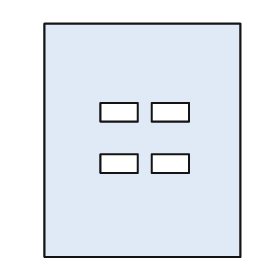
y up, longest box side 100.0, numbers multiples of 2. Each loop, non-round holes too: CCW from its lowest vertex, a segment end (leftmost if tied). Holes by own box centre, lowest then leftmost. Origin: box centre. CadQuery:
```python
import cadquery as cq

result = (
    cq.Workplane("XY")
    .moveTo(-42.0, -50.0)
    .lineTo(42.0, -50.0)
    .lineTo(42.0, 50.0)
    .lineTo(-42.0, 50.0)
    .close()
    .moveTo(-18.0, -14.0)
    .lineTo(-2.0, -14.0)
    .lineTo(-2.0, -6.0)
    .lineTo(-18.0, -6.0)
    .close()
    .moveTo(4.0, -14.0)
    .lineTo(20.0, -14.0)
    .lineTo(20.0, -6.0)
    .lineTo(4.0, -6.0)
    .close()
    .moveTo(-18.0, 8.0)
    .lineTo(-2.0, 8.0)
    .lineTo(-2.0, 16.0)
    .lineTo(-18.0, 16.0)
    .close()
    .moveTo(4.0, 8.0)
    .lineTo(20.0, 8.0)
    .lineTo(20.0, 16.0)
    .lineTo(4.0, 16.0)
    .close()
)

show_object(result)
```